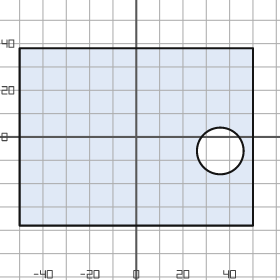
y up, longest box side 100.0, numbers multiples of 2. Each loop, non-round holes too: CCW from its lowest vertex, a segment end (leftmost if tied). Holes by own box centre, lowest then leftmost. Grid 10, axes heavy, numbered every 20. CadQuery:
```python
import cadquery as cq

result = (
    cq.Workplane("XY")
    .moveTo(-50.0, -38.0)
    .lineTo(50.0, -38.0)
    .lineTo(50.0, 38.0)
    .lineTo(-50.0, 38.0)
    .close()
    .moveTo(36.0, -6.0)
    .circle(10.0)
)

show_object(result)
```